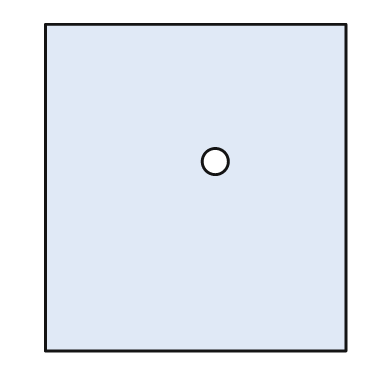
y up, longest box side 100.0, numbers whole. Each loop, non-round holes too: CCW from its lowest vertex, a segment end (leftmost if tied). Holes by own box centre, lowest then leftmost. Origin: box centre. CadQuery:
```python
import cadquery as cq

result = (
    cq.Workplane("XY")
    .moveTo(-46.0, -50.0)
    .lineTo(46.0, -50.0)
    .lineTo(46.0, 50.0)
    .lineTo(-46.0, 50.0)
    .close()
    .moveTo(6.0, 8.0)
    .circle(4.0)
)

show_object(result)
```